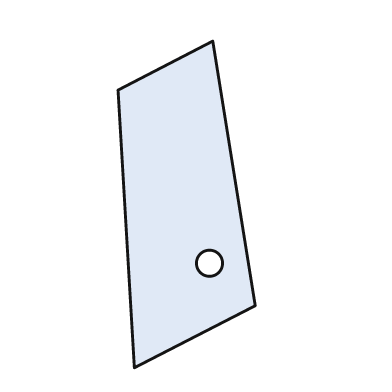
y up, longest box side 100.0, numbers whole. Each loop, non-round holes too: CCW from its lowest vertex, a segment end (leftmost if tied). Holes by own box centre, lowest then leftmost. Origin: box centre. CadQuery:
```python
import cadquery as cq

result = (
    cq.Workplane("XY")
    .moveTo(-16.0, -50.0)
    .lineTo(21.0, -31.0)
    .lineTo(8.0, 50.0)
    .lineTo(-21.0, 35.0)
    .close()
    .moveTo(7.0, -18.0)
    .circle(4.0)
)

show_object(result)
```